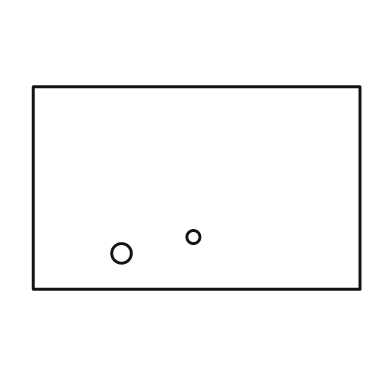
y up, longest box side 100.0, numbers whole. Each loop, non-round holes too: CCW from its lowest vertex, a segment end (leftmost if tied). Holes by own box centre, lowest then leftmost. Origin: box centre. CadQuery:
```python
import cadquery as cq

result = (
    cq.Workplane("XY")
    .moveTo(-50.0, -31.0)
    .lineTo(50.0, -31.0)
    .lineTo(50.0, 31.0)
    .lineTo(-50.0, 31.0)
    .close()
    .moveTo(-23.0, -20.0)
    .circle(3.0)
    .moveTo(-1.0, -15.0)
    .circle(2.0)
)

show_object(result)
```